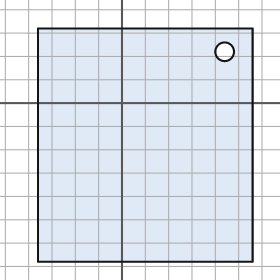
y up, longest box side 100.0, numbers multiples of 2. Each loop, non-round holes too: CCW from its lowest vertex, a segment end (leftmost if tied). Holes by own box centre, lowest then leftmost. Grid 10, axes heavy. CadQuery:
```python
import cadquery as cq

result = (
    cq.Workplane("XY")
    .moveTo(-36.0, -68.0)
    .lineTo(56.0, -68.0)
    .lineTo(56.0, 32.0)
    .lineTo(-36.0, 32.0)
    .close()
    .moveTo(44.0, 22.0)
    .circle(4.0)
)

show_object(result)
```